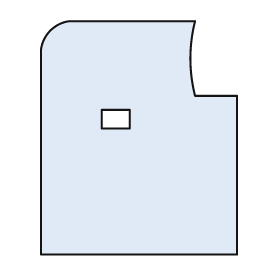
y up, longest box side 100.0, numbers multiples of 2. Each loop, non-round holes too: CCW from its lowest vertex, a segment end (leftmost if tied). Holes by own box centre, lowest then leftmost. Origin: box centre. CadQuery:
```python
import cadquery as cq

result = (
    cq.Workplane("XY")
    .moveTo(-42.0, -50.0)
    .lineTo(42.0, -50.0)
    .lineTo(42.0, 18.0)
    .lineTo(24.0, 18.0)
    .threePointArc((22.0, 34.0), (24.0, 50.0))
    .lineTo(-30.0, 50.0)
    .threePointArc((-38.0, 46.0), (-42.0, 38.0))
    .close()
    .moveTo(-16.0, 4.0)
    .lineTo(-4.0, 4.0)
    .lineTo(-4.0, 12.0)
    .lineTo(-16.0, 12.0)
    .close()
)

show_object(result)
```